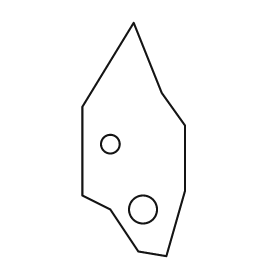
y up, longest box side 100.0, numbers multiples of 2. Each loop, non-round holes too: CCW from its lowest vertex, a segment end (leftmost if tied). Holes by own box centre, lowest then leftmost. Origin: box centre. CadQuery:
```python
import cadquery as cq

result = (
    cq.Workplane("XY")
    .moveTo(14.0, -50.0)
    .lineTo(22.0, -22.0)
    .lineTo(22.0, 6.0)
    .lineTo(12.0, 20.0)
    .lineTo(0.0, 50.0)
    .lineTo(-22.0, 14.0)
    .lineTo(-22.0, -24.0)
    .lineTo(-10.0, -30.0)
    .lineTo(2.0, -48.0)
    .close()
    .moveTo(4.0, -30.0)
    .circle(6.0)
    .moveTo(-10.0, -2.0)
    .circle(4.0)
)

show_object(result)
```